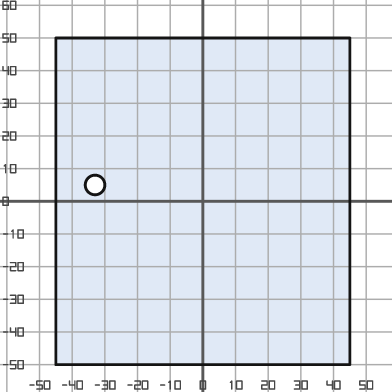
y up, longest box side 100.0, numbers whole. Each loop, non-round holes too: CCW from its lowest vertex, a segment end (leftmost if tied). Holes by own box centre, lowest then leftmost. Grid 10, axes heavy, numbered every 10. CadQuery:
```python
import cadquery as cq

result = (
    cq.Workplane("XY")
    .moveTo(-45.0, -50.0)
    .lineTo(45.0, -50.0)
    .lineTo(45.0, 50.0)
    .lineTo(-45.0, 50.0)
    .close()
    .moveTo(-33.0, 5.0)
    .circle(3.0)
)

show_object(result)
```